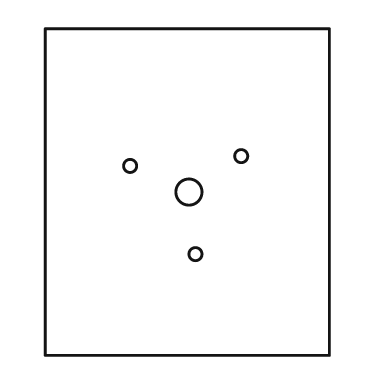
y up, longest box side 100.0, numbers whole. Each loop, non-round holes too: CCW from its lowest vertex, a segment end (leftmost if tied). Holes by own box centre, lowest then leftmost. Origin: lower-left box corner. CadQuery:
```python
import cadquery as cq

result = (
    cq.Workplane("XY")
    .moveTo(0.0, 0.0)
    .lineTo(87.0, 0.0)
    .lineTo(87.0, 100.0)
    .lineTo(0.0, 100.0)
    .close()
    .moveTo(46.0, 31.0)
    .circle(2.0)
    .moveTo(44.0, 50.0)
    .circle(4.0)
    .moveTo(26.0, 58.0)
    .circle(2.0)
    .moveTo(60.0, 61.0)
    .circle(2.0)
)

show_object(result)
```